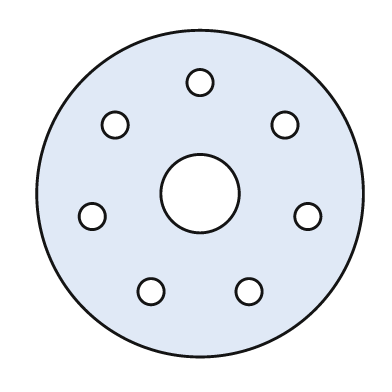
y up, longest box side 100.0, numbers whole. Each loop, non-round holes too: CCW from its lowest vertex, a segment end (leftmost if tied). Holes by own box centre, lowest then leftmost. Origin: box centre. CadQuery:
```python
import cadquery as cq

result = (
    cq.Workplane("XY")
    .moveTo(0.0, 0.0)
    .circle(50.0)
    .moveTo(-15.0, -30.0)
    .circle(4.0)
    .moveTo(15.0, -30.0)
    .circle(4.0)
    .moveTo(-33.0, -7.0)
    .circle(4.0)
    .moveTo(33.0, -7.0)
    .circle(4.0)
    .moveTo(0.0, 0.0)
    .circle(12.0)
    .moveTo(-26.0, 21.0)
    .circle(4.0)
    .moveTo(26.0, 21.0)
    .circle(4.0)
    .moveTo(0.0, 34.0)
    .circle(4.0)
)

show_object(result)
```